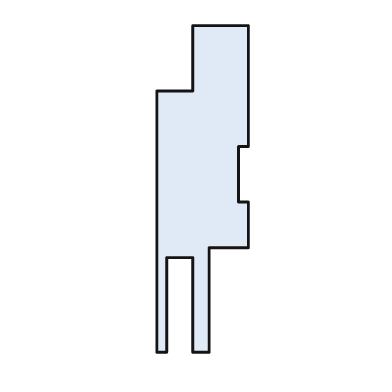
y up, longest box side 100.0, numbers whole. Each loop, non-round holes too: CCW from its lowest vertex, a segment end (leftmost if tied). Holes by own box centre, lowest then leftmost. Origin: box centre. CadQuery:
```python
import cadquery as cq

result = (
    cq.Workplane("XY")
    .moveTo(-14.0, -50.0)
    .lineTo(-11.0, -50.0)
    .lineTo(-11.0, -21.0)
    .lineTo(-3.0, -21.0)
    .lineTo(-3.0, -50.0)
    .lineTo(2.0, -50.0)
    .lineTo(2.0, -18.0)
    .lineTo(14.0, -18.0)
    .lineTo(14.0, -4.0)
    .lineTo(11.0, -4.0)
    .lineTo(11.0, 13.0)
    .lineTo(14.0, 13.0)
    .lineTo(14.0, 50.0)
    .lineTo(-3.0, 50.0)
    .lineTo(-3.0, 30.0)
    .lineTo(-14.0, 30.0)
    .close()
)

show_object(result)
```